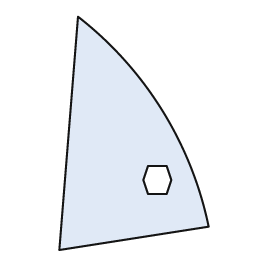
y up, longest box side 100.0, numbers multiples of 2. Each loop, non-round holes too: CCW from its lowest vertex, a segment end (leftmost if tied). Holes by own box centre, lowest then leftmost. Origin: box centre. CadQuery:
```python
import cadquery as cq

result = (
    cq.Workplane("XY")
    .moveTo(-32.0, -50.0)
    .lineTo(32.0, -40.0)
    .threePointArc((12.0, 10.0), (-24.0, 50.0))
    .close()
    .moveTo(6.0, -26.0)
    .lineTo(14.0, -26.0)
    .lineTo(16.0, -20.0)
    .lineTo(14.0, -14.0)
    .lineTo(6.0, -14.0)
    .lineTo(4.0, -20.0)
    .close()
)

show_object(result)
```